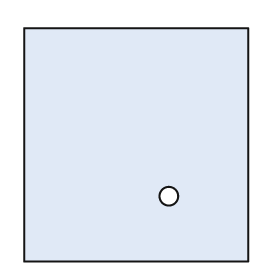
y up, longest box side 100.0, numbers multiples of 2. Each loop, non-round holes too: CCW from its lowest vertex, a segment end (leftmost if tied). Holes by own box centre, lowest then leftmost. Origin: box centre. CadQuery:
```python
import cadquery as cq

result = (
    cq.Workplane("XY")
    .moveTo(-48.0, -50.0)
    .lineTo(48.0, -50.0)
    .lineTo(48.0, 50.0)
    .lineTo(-48.0, 50.0)
    .close()
    .moveTo(14.0, -22.0)
    .circle(4.0)
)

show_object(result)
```